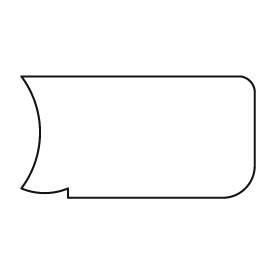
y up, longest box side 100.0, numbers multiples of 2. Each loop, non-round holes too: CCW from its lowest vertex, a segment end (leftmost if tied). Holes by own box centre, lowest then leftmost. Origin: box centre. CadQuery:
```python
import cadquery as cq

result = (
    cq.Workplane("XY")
    .moveTo(-30.0, -26.0)
    .lineTo(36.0, -26.0)
    .threePointArc((46.0, -22.0), (50.0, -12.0))
    .lineTo(50.0, 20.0)
    .threePointArc((48.0, 24.0), (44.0, 26.0))
    .lineTo(-50.0, 26.0)
    .threePointArc((-42.0, 2.0), (-50.0, -22.0))
    .threePointArc((-40.0, -24.0), (-30.0, -22.0))
    .close()
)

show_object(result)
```